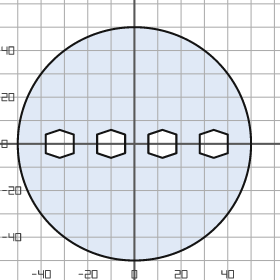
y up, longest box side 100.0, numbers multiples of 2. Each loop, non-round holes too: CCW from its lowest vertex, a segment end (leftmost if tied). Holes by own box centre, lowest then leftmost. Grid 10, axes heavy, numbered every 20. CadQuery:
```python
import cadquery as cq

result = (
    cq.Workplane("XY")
    .moveTo(0.0, 0.0)
    .circle(50.0)
    .moveTo(-32.0, -6.0)
    .lineTo(-26.0, -4.0)
    .lineTo(-26.0, 4.0)
    .lineTo(-32.0, 6.0)
    .lineTo(-38.0, 4.0)
    .lineTo(-38.0, -4.0)
    .close()
    .moveTo(-10.0, -6.0)
    .lineTo(-4.0, -4.0)
    .lineTo(-4.0, 4.0)
    .lineTo(-10.0, 6.0)
    .lineTo(-16.0, 4.0)
    .lineTo(-16.0, -4.0)
    .close()
    .moveTo(12.0, -6.0)
    .lineTo(18.0, -4.0)
    .lineTo(18.0, 4.0)
    .lineTo(12.0, 6.0)
    .lineTo(6.0, 4.0)
    .lineTo(6.0, -4.0)
    .close()
    .moveTo(34.0, -6.0)
    .lineTo(40.0, -4.0)
    .lineTo(40.0, 4.0)
    .lineTo(34.0, 6.0)
    .lineTo(28.0, 4.0)
    .lineTo(28.0, -4.0)
    .close()
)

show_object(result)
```